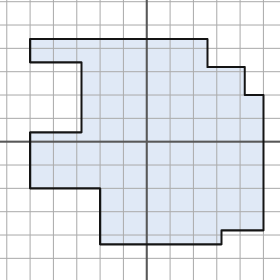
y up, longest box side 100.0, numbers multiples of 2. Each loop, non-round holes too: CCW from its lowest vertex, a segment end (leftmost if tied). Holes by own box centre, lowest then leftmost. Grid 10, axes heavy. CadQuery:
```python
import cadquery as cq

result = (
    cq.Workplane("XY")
    .moveTo(-20.0, -44.0)
    .lineTo(32.0, -44.0)
    .lineTo(32.0, -38.0)
    .lineTo(50.0, -38.0)
    .lineTo(50.0, 20.0)
    .lineTo(42.0, 20.0)
    .lineTo(42.0, 32.0)
    .lineTo(26.0, 32.0)
    .lineTo(26.0, 44.0)
    .lineTo(-50.0, 44.0)
    .lineTo(-50.0, 34.0)
    .lineTo(-28.0, 34.0)
    .lineTo(-28.0, 4.0)
    .lineTo(-50.0, 4.0)
    .lineTo(-50.0, -20.0)
    .lineTo(-20.0, -20.0)
    .close()
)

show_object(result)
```